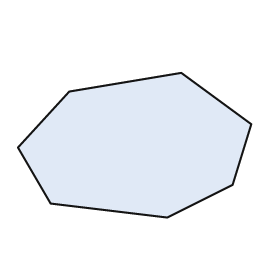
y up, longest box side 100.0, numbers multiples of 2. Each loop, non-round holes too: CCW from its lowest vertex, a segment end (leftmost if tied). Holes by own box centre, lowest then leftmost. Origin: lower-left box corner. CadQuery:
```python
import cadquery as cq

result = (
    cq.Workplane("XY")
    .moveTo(64.0, 0.0)
    .lineTo(92.0, 14.0)
    .lineTo(100.0, 40.0)
    .lineTo(70.0, 62.0)
    .lineTo(22.0, 54.0)
    .lineTo(0.0, 30.0)
    .lineTo(14.0, 6.0)
    .close()
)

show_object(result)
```